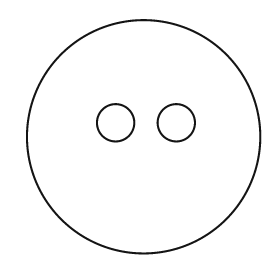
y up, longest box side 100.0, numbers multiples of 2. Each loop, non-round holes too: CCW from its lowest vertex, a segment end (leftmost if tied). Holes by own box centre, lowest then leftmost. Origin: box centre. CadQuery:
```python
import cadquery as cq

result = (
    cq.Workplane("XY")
    .moveTo(0.0, 0.0)
    .circle(50.0)
    .moveTo(-12.0, 6.0)
    .circle(8.0)
    .moveTo(14.0, 6.0)
    .circle(8.0)
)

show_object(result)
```